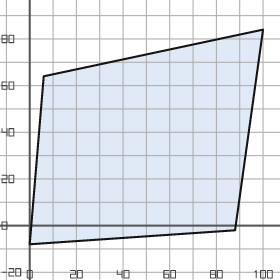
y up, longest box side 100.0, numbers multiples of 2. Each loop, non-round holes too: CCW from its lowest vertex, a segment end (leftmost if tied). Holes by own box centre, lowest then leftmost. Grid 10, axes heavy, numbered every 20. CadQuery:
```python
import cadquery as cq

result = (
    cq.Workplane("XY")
    .moveTo(0.0, -8.0)
    .lineTo(88.0, -2.0)
    .lineTo(100.0, 84.0)
    .lineTo(6.0, 64.0)
    .close()
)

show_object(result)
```